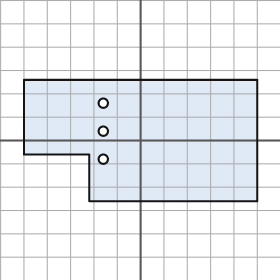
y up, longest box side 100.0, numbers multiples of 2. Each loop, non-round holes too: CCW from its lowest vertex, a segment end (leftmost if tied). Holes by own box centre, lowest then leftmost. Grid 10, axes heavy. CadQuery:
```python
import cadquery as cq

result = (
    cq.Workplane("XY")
    .moveTo(-22.0, -26.0)
    .lineTo(50.0, -26.0)
    .lineTo(50.0, 26.0)
    .lineTo(-50.0, 26.0)
    .lineTo(-50.0, -6.0)
    .lineTo(-22.0, -6.0)
    .close()
    .moveTo(-16.0, -8.0)
    .circle(2.0)
    .moveTo(-16.0, 4.0)
    .circle(2.0)
    .moveTo(-16.0, 16.0)
    .circle(2.0)
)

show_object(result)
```